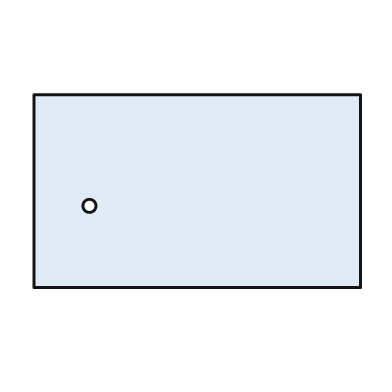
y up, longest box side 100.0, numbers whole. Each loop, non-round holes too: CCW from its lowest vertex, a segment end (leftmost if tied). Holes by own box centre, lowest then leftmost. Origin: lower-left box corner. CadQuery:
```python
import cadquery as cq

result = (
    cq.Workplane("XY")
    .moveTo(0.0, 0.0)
    .lineTo(100.0, 0.0)
    .lineTo(100.0, 59.0)
    .lineTo(0.0, 59.0)
    .close()
    .moveTo(17.0, 25.0)
    .circle(2.0)
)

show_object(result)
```